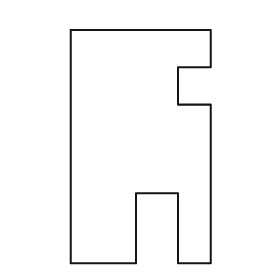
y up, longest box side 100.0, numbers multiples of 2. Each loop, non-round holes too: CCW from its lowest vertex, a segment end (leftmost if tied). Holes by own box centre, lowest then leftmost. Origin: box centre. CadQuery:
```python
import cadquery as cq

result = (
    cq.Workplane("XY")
    .moveTo(-30.0, -50.0)
    .lineTo(-2.0, -50.0)
    .lineTo(-2.0, -20.0)
    .lineTo(16.0, -20.0)
    .lineTo(16.0, -50.0)
    .lineTo(30.0, -50.0)
    .lineTo(30.0, 18.0)
    .lineTo(16.0, 18.0)
    .lineTo(16.0, 34.0)
    .lineTo(30.0, 34.0)
    .lineTo(30.0, 50.0)
    .lineTo(-30.0, 50.0)
    .close()
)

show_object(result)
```